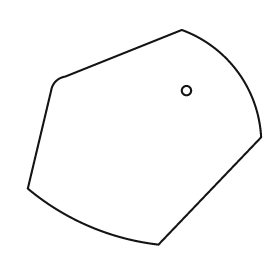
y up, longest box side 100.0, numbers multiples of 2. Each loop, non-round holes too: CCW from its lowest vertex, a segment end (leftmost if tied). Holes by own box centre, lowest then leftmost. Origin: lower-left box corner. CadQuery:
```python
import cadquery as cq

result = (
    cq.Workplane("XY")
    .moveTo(56.0, 0.0)
    .lineTo(100.0, 46.0)
    .threePointArc((90.0, 74.0), (66.0, 92.0))
    .lineTo(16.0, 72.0)
    .threePointArc((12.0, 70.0), (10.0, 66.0))
    .lineTo(0.0, 24.0)
    .threePointArc((26.0, 8.0), (56.0, 0.0))
    .close()
    .moveTo(68.0, 66.0)
    .circle(2.0)
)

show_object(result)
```